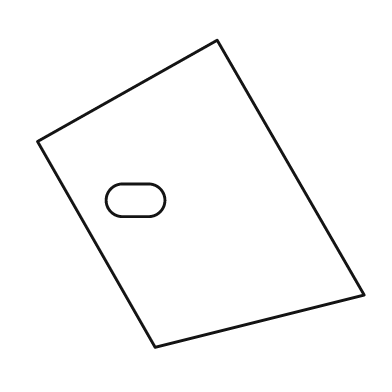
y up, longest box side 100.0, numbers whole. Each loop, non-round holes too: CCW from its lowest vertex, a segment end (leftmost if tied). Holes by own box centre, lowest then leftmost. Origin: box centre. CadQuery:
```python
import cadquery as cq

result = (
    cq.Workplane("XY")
    .moveTo(-14.0, -47.0)
    .lineTo(50.0, -31.0)
    .lineTo(5.0, 47.0)
    .lineTo(-50.0, 16.0)
    .close()
    .moveTo(-24.0, -7.0)
    .lineTo(-16.0, -7.0)
    .threePointArc((-11.0, -2.0), (-16.0, 3.0))
    .lineTo(-24.0, 3.0)
    .threePointArc((-29.0, -2.0), (-24.0, -7.0))
    .close()
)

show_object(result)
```